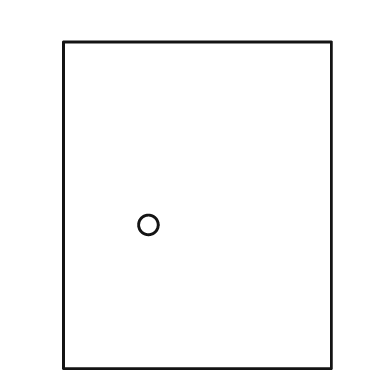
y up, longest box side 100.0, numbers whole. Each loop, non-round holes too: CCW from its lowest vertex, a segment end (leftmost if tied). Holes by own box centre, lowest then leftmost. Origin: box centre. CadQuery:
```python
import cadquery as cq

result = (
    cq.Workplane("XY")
    .moveTo(-41.0, -50.0)
    .lineTo(41.0, -50.0)
    .lineTo(41.0, 50.0)
    .lineTo(-41.0, 50.0)
    .close()
    .moveTo(-15.0, -6.0)
    .circle(3.0)
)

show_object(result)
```